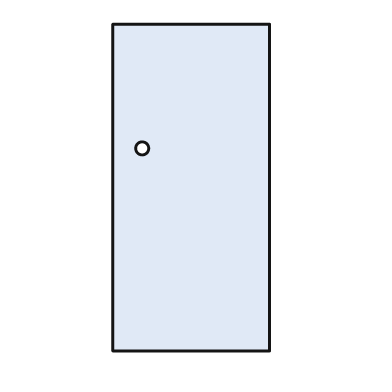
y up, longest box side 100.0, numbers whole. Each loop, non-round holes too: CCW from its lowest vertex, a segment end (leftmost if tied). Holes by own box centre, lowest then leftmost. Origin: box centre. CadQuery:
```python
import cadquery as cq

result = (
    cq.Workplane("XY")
    .moveTo(-24.0, -50.0)
    .lineTo(24.0, -50.0)
    .lineTo(24.0, 50.0)
    .lineTo(-24.0, 50.0)
    .close()
    .moveTo(-15.0, 12.0)
    .circle(2.0)
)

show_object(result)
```